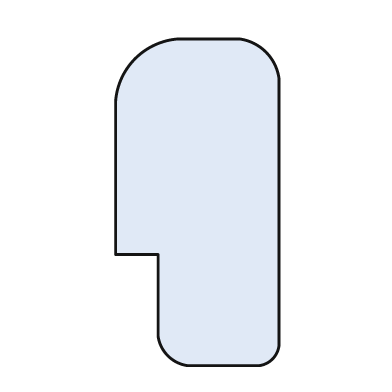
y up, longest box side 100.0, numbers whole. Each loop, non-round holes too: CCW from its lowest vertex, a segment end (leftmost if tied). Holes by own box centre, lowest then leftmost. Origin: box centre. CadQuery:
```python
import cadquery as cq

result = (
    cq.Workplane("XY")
    .moveTo(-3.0, -50.0)
    .lineTo(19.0, -50.0)
    .threePointArc((23.0, -48.0), (25.0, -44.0))
    .lineTo(25.0, 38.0)
    .threePointArc((21.0, 46.0), (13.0, 50.0))
    .lineTo(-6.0, 50.0)
    .threePointArc((-19.0, 44.0), (-25.0, 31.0))
    .lineTo(-25.0, -16.0)
    .lineTo(-12.0, -16.0)
    .lineTo(-12.0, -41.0)
    .threePointArc((-9.0, -47.0), (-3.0, -50.0))
    .close()
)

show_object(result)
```